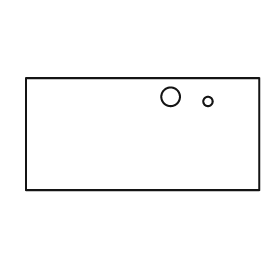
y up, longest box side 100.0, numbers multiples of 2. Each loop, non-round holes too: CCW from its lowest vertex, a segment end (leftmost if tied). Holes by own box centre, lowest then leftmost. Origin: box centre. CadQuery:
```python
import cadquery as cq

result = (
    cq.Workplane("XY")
    .moveTo(-50.0, -24.0)
    .lineTo(50.0, -24.0)
    .lineTo(50.0, 24.0)
    .lineTo(-50.0, 24.0)
    .close()
    .moveTo(28.0, 14.0)
    .circle(2.0)
    .moveTo(12.0, 16.0)
    .circle(4.0)
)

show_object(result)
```